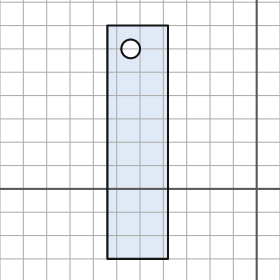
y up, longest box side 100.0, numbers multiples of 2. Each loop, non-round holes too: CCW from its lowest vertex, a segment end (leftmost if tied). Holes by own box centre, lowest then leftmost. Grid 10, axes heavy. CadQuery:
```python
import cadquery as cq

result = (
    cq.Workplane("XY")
    .moveTo(-64.0, -30.0)
    .lineTo(-38.0, -30.0)
    .lineTo(-38.0, 70.0)
    .lineTo(-64.0, 70.0)
    .close()
    .moveTo(-54.0, 60.0)
    .circle(4.0)
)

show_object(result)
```